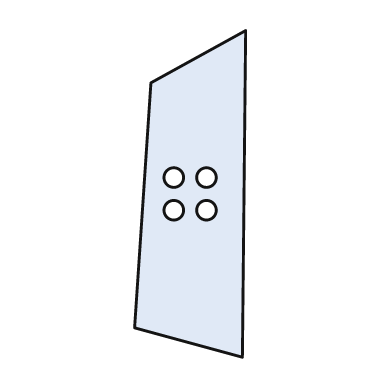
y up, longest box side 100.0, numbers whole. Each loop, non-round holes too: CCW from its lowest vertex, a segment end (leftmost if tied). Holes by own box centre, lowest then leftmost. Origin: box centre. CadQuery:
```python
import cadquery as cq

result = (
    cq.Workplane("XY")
    .moveTo(16.0, -50.0)
    .lineTo(17.0, 50.0)
    .lineTo(-12.0, 34.0)
    .lineTo(-17.0, -41.0)
    .close()
    .moveTo(-5.0, -5.0)
    .circle(3.0)
    .moveTo(5.0, -5.0)
    .circle(3.0)
    .moveTo(-5.0, 5.0)
    .circle(3.0)
    .moveTo(5.0, 5.0)
    .circle(3.0)
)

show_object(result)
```